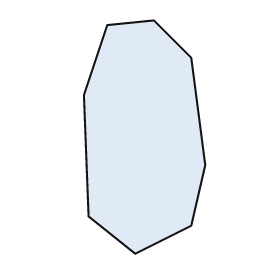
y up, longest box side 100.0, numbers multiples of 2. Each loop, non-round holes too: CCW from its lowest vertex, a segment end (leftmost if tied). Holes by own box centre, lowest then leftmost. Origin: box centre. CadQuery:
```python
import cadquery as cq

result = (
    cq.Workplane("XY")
    .moveTo(-4.0, -50.0)
    .lineTo(20.0, -38.0)
    .lineTo(26.0, -12.0)
    .lineTo(20.0, 34.0)
    .lineTo(4.0, 50.0)
    .lineTo(-16.0, 48.0)
    .lineTo(-26.0, 18.0)
    .lineTo(-24.0, -34.0)
    .close()
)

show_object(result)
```